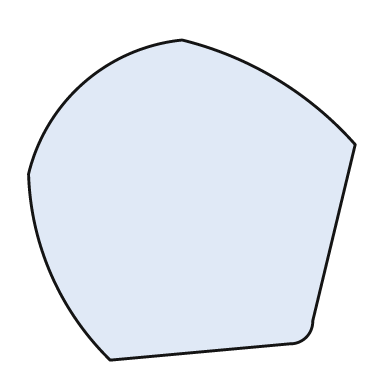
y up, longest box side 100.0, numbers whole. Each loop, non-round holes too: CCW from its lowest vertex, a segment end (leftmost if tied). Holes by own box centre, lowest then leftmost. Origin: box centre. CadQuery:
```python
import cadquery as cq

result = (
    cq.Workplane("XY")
    .moveTo(-25.0, -49.0)
    .lineTo(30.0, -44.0)
    .threePointArc((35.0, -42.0), (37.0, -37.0))
    .lineTo(50.0, 17.0)
    .threePointArc((26.0, 37.0), (-3.0, 49.0))
    .threePointArc((-33.0, 36.0), (-50.0, 8.0))
    .threePointArc((-43.0, -23.0), (-25.0, -49.0))
    .close()
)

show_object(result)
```